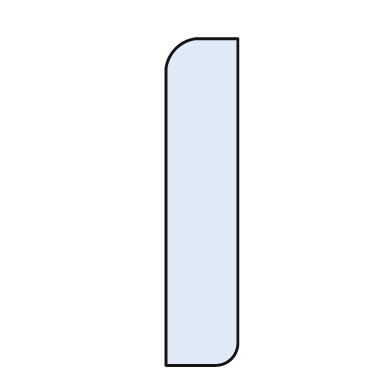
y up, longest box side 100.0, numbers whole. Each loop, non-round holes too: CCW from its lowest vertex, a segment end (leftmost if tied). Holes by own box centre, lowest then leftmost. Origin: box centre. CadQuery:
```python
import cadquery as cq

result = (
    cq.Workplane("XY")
    .moveTo(-11.0, -50.0)
    .lineTo(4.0, -50.0)
    .threePointArc((9.0, -48.0), (11.0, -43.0))
    .lineTo(11.0, 50.0)
    .lineTo(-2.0, 50.0)
    .threePointArc((-8.0, 47.0), (-11.0, 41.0))
    .close()
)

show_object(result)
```